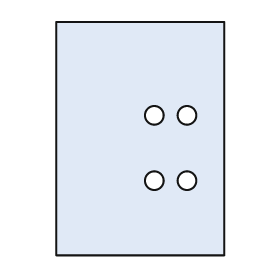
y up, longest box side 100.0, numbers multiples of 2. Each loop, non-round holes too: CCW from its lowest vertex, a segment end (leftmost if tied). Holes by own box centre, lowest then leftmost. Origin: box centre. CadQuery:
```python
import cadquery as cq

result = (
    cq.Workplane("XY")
    .moveTo(-36.0, -50.0)
    .lineTo(36.0, -50.0)
    .lineTo(36.0, 50.0)
    .lineTo(-36.0, 50.0)
    .close()
    .moveTo(6.0, -18.0)
    .circle(4.0)
    .moveTo(20.0, -18.0)
    .circle(4.0)
    .moveTo(6.0, 10.0)
    .circle(4.0)
    .moveTo(20.0, 10.0)
    .circle(4.0)
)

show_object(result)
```